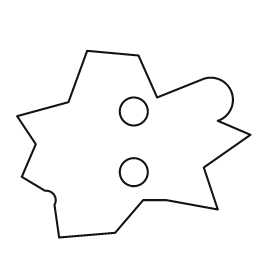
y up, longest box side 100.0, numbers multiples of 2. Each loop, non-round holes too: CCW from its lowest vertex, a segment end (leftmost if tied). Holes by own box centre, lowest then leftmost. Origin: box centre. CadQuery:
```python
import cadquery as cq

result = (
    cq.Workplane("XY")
    .moveTo(-32.0, -40.0)
    .lineTo(-8.0, -38.0)
    .lineTo(4.0, -24.0)
    .lineTo(14.0, -24.0)
    .lineTo(36.0, -28.0)
    .lineTo(30.0, -10.0)
    .lineTo(50.0, 4.0)
    .lineTo(36.0, 10.0)
    .threePointArc((42.0, 22.0), (30.0, 28.0))
    .lineTo(10.0, 20.0)
    .lineTo(2.0, 38.0)
    .lineTo(-20.0, 40.0)
    .lineTo(-28.0, 18.0)
    .lineTo(-50.0, 12.0)
    .lineTo(-42.0, 0.0)
    .lineTo(-48.0, -14.0)
    .lineTo(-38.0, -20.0)
    .threePointArc((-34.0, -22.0), (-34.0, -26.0))
    .close()
    .moveTo(0.0, -12.0)
    .circle(6.0)
    .moveTo(0.0, 14.0)
    .circle(6.0)
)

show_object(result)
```